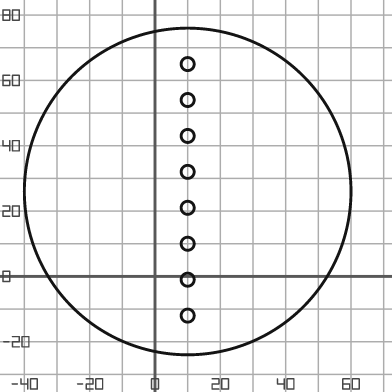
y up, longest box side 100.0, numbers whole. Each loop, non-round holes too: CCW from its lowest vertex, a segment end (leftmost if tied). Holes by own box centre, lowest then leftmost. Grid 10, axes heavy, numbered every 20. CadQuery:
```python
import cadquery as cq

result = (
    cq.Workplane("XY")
    .moveTo(10.0, 26.0)
    .circle(50.0)
    .moveTo(10.0, -12.0)
    .circle(2.0)
    .moveTo(10.0, -1.0)
    .circle(2.0)
    .moveTo(10.0, 10.0)
    .circle(2.0)
    .moveTo(10.0, 21.0)
    .circle(2.0)
    .moveTo(10.0, 32.0)
    .circle(2.0)
    .moveTo(10.0, 43.0)
    .circle(2.0)
    .moveTo(10.0, 54.0)
    .circle(2.0)
    .moveTo(10.0, 65.0)
    .circle(2.0)
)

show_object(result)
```